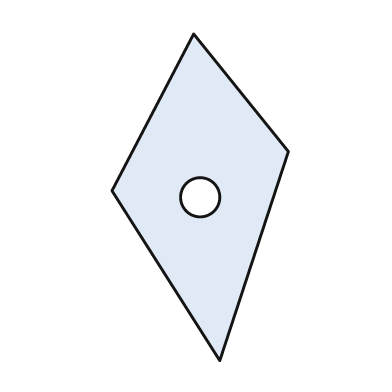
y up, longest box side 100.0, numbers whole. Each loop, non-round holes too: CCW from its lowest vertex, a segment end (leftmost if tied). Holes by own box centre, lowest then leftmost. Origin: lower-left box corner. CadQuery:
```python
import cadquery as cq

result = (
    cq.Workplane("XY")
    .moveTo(33.0, 0.0)
    .lineTo(54.0, 64.0)
    .lineTo(25.0, 100.0)
    .lineTo(0.0, 52.0)
    .close()
    .moveTo(27.0, 50.0)
    .circle(6.0)
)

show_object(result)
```